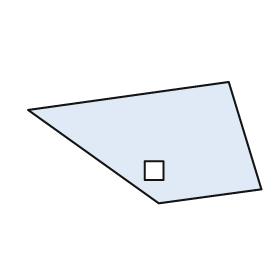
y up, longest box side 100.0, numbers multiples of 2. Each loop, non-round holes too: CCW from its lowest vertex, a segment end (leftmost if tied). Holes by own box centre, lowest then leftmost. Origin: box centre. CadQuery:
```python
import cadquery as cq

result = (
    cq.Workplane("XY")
    .moveTo(6.0, -26.0)
    .lineTo(50.0, -20.0)
    .lineTo(36.0, 26.0)
    .lineTo(-50.0, 14.0)
    .close()
    .moveTo(0.0, -16.0)
    .lineTo(8.0, -16.0)
    .lineTo(8.0, -8.0)
    .lineTo(0.0, -8.0)
    .close()
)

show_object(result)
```